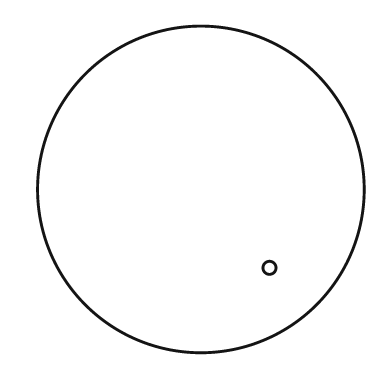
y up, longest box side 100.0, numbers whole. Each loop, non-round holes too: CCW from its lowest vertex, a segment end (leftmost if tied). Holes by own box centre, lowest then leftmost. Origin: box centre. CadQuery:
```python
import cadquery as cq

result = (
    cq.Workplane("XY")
    .moveTo(0.0, 0.0)
    .circle(50.0)
    .moveTo(21.0, -24.0)
    .circle(2.0)
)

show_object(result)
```